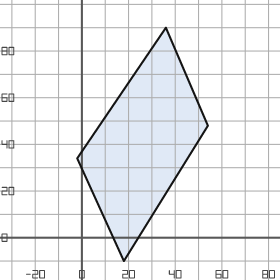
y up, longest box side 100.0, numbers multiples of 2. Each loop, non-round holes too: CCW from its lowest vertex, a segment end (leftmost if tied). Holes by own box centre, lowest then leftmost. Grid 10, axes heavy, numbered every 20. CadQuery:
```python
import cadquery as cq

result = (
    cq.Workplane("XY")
    .moveTo(18.0, -10.0)
    .lineTo(54.0, 48.0)
    .lineTo(36.0, 90.0)
    .lineTo(-2.0, 34.0)
    .close()
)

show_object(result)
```